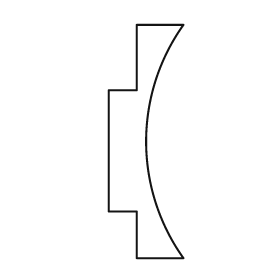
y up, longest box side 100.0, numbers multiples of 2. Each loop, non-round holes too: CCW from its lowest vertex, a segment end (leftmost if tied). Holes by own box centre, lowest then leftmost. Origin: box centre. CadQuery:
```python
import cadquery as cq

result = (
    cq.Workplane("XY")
    .moveTo(-4.0, -50.0)
    .lineTo(16.0, -50.0)
    .threePointArc((0.0, 0.0), (16.0, 50.0))
    .lineTo(-4.0, 50.0)
    .lineTo(-4.0, 22.0)
    .lineTo(-16.0, 22.0)
    .lineTo(-16.0, -30.0)
    .lineTo(-4.0, -30.0)
    .close()
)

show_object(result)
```